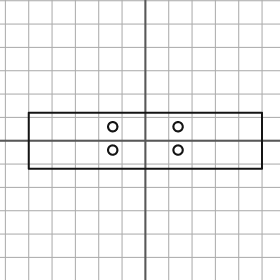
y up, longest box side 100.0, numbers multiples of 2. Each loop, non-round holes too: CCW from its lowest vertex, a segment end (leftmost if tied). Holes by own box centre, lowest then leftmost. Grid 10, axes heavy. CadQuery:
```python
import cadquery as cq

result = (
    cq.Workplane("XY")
    .moveTo(-50.0, -12.0)
    .lineTo(50.0, -12.0)
    .lineTo(50.0, 12.0)
    .lineTo(-50.0, 12.0)
    .close()
    .moveTo(-14.0, -4.0)
    .circle(2.0)
    .moveTo(14.0, -4.0)
    .circle(2.0)
    .moveTo(-14.0, 6.0)
    .circle(2.0)
    .moveTo(14.0, 6.0)
    .circle(2.0)
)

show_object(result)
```